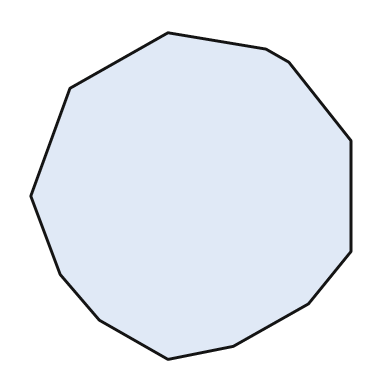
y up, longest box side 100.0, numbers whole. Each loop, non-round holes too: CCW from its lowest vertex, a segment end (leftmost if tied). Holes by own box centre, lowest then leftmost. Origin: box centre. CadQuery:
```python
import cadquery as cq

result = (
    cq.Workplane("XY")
    .moveTo(-7.0, -50.0)
    .lineTo(13.0, -46.0)
    .lineTo(36.0, -33.0)
    .lineTo(49.0, -17.0)
    .lineTo(49.0, 17.0)
    .lineTo(30.0, 41.0)
    .lineTo(23.0, 45.0)
    .lineTo(-7.0, 50.0)
    .lineTo(-37.0, 33.0)
    .lineTo(-49.0, 0.0)
    .lineTo(-40.0, -24.0)
    .lineTo(-28.0, -38.0)
    .close()
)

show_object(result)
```